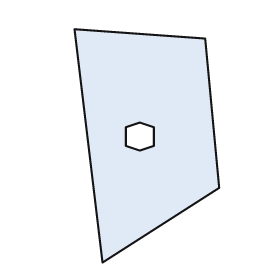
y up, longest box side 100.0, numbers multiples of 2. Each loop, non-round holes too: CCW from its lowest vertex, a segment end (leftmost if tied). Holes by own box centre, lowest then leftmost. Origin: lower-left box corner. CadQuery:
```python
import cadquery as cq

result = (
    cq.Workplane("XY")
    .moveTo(12.0, 0.0)
    .lineTo(62.0, 32.0)
    .lineTo(56.0, 96.0)
    .lineTo(0.0, 100.0)
    .close()
    .moveTo(28.0, 48.0)
    .lineTo(34.0, 50.0)
    .lineTo(34.0, 58.0)
    .lineTo(28.0, 60.0)
    .lineTo(22.0, 58.0)
    .lineTo(22.0, 50.0)
    .close()
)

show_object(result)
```